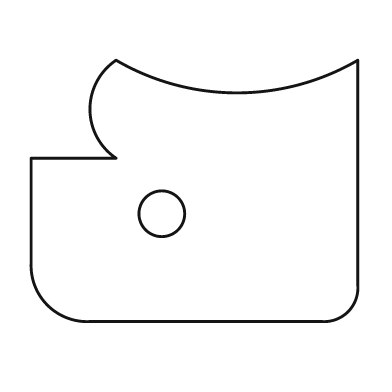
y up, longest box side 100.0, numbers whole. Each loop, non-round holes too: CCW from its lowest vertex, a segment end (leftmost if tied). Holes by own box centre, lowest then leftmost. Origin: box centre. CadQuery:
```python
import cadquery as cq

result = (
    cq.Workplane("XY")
    .moveTo(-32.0, -40.0)
    .lineTo(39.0, -40.0)
    .threePointArc((47.0, -37.0), (50.0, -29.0))
    .lineTo(50.0, 40.0)
    .threePointArc((13.0, 30.0), (-24.0, 40.0))
    .threePointArc((-32.0, 25.0), (-24.0, 10.0))
    .lineTo(-50.0, 10.0)
    .lineTo(-50.0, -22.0)
    .threePointArc((-45.0, -35.0), (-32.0, -40.0))
    .close()
    .moveTo(-10.0, -7.0)
    .circle(7.0)
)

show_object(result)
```